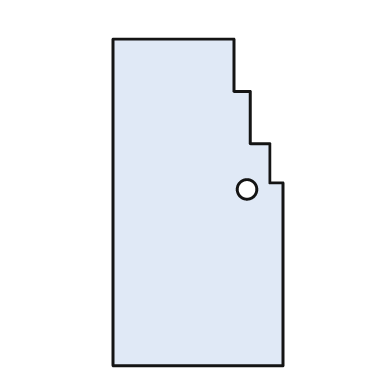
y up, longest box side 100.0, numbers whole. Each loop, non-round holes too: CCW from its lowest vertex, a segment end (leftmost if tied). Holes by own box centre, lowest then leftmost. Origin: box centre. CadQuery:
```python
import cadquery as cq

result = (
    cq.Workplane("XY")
    .moveTo(-26.0, -50.0)
    .lineTo(26.0, -50.0)
    .lineTo(26.0, 6.0)
    .lineTo(22.0, 6.0)
    .lineTo(22.0, 18.0)
    .lineTo(16.0, 18.0)
    .lineTo(16.0, 34.0)
    .lineTo(11.0, 34.0)
    .lineTo(11.0, 50.0)
    .lineTo(-26.0, 50.0)
    .close()
    .moveTo(15.0, 4.0)
    .circle(3.0)
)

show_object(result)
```